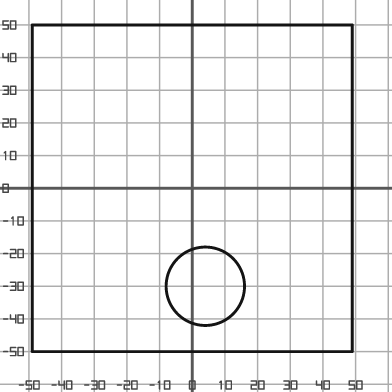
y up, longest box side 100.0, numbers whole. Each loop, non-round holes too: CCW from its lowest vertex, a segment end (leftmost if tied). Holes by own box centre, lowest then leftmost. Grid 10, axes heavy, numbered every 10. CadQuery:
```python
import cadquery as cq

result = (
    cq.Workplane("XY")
    .moveTo(-49.0, -50.0)
    .lineTo(49.0, -50.0)
    .lineTo(49.0, 50.0)
    .lineTo(-49.0, 50.0)
    .close()
    .moveTo(4.0, -30.0)
    .circle(12.0)
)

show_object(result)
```